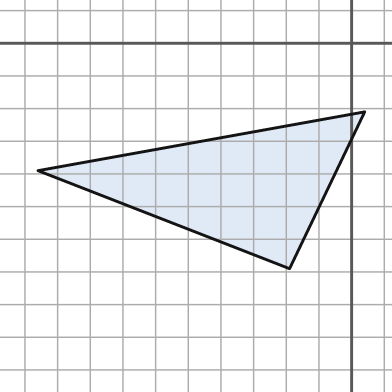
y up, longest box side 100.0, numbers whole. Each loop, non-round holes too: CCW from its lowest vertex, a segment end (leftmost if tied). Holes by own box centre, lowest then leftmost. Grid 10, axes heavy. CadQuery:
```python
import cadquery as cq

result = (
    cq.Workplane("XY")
    .moveTo(-19.0, -69.0)
    .lineTo(4.0, -21.0)
    .lineTo(-96.0, -39.0)
    .close()
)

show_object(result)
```